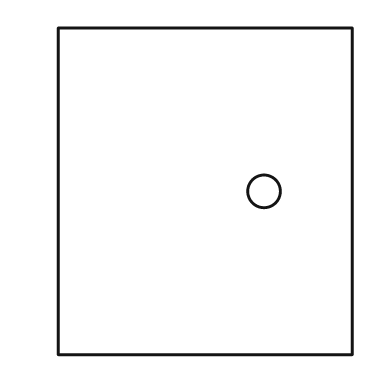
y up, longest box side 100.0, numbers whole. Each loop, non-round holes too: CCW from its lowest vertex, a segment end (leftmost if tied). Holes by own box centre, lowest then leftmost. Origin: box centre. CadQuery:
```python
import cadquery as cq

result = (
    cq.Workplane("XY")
    .moveTo(-45.0, -50.0)
    .lineTo(45.0, -50.0)
    .lineTo(45.0, 50.0)
    .lineTo(-45.0, 50.0)
    .close()
    .moveTo(18.0, 0.0)
    .circle(5.0)
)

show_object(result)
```